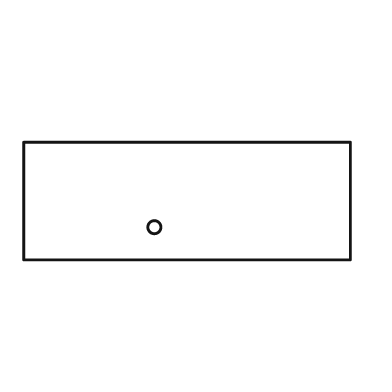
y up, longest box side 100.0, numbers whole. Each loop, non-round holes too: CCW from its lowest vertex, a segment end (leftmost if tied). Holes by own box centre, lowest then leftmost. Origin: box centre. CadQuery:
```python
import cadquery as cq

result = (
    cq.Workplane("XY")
    .moveTo(-50.0, -18.0)
    .lineTo(50.0, -18.0)
    .lineTo(50.0, 18.0)
    .lineTo(-50.0, 18.0)
    .close()
    .moveTo(-10.0, -8.0)
    .circle(2.0)
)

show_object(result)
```